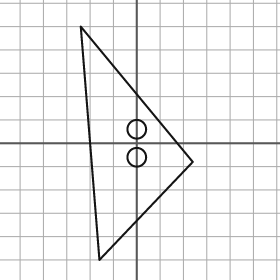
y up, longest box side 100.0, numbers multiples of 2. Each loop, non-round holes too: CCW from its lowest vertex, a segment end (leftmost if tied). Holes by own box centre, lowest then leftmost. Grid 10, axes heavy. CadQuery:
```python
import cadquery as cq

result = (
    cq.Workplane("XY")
    .moveTo(-16.0, -50.0)
    .lineTo(24.0, -8.0)
    .lineTo(-24.0, 50.0)
    .close()
    .moveTo(0.0, -6.0)
    .circle(4.0)
    .moveTo(0.0, 6.0)
    .circle(4.0)
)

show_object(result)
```